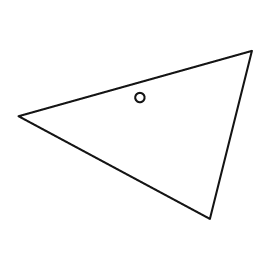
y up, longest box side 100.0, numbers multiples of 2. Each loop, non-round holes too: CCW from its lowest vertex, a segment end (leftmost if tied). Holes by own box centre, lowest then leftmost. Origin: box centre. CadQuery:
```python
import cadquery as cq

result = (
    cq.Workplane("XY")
    .moveTo(32.0, -36.0)
    .lineTo(50.0, 36.0)
    .lineTo(-50.0, 8.0)
    .close()
    .moveTo(2.0, 16.0)
    .circle(2.0)
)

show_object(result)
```